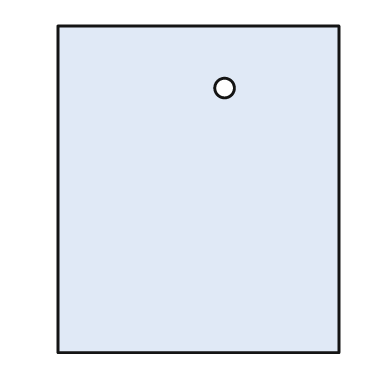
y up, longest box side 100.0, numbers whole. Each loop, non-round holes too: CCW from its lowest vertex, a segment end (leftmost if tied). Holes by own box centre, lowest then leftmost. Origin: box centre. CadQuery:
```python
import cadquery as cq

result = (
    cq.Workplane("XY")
    .moveTo(-43.0, -50.0)
    .lineTo(43.0, -50.0)
    .lineTo(43.0, 50.0)
    .lineTo(-43.0, 50.0)
    .close()
    .moveTo(8.0, 31.0)
    .circle(3.0)
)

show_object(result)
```